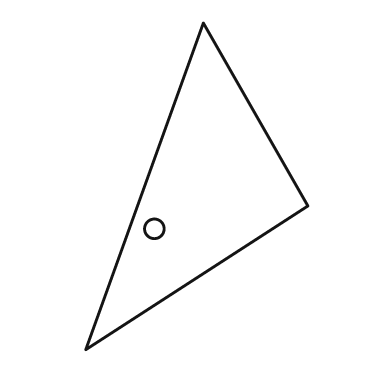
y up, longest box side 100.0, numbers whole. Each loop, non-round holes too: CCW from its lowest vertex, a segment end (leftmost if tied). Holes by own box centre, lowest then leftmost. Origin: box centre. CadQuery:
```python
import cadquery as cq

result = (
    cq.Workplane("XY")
    .moveTo(-34.0, -50.0)
    .lineTo(34.0, -6.0)
    .lineTo(2.0, 50.0)
    .close()
    .moveTo(-13.0, -13.0)
    .circle(3.0)
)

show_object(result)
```